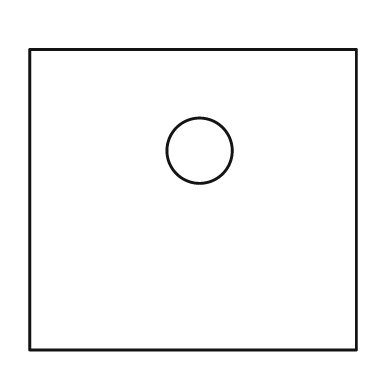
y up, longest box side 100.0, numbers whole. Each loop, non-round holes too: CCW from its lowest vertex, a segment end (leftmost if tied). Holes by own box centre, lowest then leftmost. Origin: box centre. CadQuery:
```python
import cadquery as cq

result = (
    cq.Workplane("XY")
    .moveTo(-50.0, -46.0)
    .lineTo(50.0, -46.0)
    .lineTo(50.0, 46.0)
    .lineTo(-50.0, 46.0)
    .close()
    .moveTo(2.0, 15.0)
    .circle(10.0)
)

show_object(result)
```